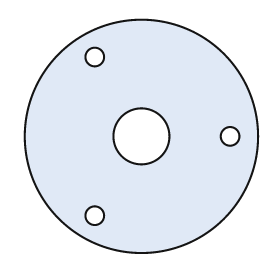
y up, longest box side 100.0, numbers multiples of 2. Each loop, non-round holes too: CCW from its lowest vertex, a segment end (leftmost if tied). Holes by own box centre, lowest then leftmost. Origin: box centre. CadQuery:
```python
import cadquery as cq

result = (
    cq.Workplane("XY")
    .moveTo(0.0, 0.0)
    .circle(50.0)
    .moveTo(-20.0, -34.0)
    .circle(4.0)
    .moveTo(0.0, 0.0)
    .circle(12.0)
    .moveTo(38.0, 0.0)
    .circle(4.0)
    .moveTo(-20.0, 34.0)
    .circle(4.0)
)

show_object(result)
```